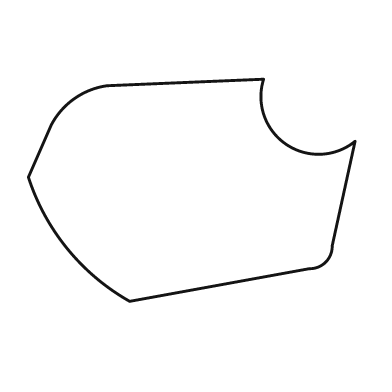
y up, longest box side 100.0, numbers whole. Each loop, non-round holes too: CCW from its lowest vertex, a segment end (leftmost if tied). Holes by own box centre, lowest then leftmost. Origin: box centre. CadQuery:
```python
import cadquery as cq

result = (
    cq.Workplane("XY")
    .moveTo(-19.0, -34.0)
    .lineTo(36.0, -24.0)
    .threePointArc((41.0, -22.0), (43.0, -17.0))
    .lineTo(50.0, 15.0)
    .threePointArc((29.0, 14.0), (22.0, 34.0))
    .lineTo(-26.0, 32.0)
    .threePointArc((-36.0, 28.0), (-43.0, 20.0))
    .lineTo(-50.0, 4.0)
    .threePointArc((-38.0, -18.0), (-19.0, -34.0))
    .close()
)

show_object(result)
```